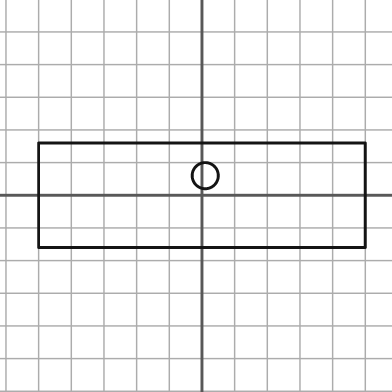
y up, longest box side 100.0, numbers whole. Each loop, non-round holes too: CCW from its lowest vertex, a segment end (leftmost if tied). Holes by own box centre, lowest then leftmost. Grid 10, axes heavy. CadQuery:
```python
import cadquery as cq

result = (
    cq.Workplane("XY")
    .moveTo(-50.0, -16.0)
    .lineTo(50.0, -16.0)
    .lineTo(50.0, 16.0)
    .lineTo(-50.0, 16.0)
    .close()
    .moveTo(1.0, 6.0)
    .circle(4.0)
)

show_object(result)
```